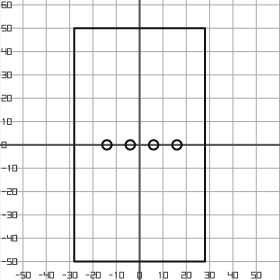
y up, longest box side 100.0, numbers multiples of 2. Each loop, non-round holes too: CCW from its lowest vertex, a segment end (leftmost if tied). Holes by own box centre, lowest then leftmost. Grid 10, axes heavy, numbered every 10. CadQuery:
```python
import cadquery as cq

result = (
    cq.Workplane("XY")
    .moveTo(-28.0, -50.0)
    .lineTo(28.0, -50.0)
    .lineTo(28.0, 50.0)
    .lineTo(-28.0, 50.0)
    .close()
    .moveTo(-14.0, 0.0)
    .circle(2.0)
    .moveTo(-4.0, 0.0)
    .circle(2.0)
    .moveTo(6.0, 0.0)
    .circle(2.0)
    .moveTo(16.0, 0.0)
    .circle(2.0)
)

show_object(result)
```